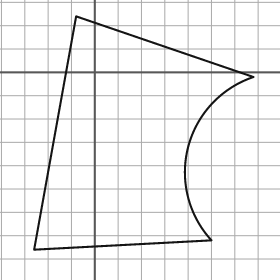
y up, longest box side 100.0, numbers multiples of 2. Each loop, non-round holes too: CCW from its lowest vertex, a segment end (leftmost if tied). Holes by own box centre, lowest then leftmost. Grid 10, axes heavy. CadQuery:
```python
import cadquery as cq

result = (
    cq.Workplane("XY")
    .moveTo(-26.0, -76.0)
    .lineTo(50.0, -72.0)
    .threePointArc((40.0, -32.0), (68.0, -2.0))
    .lineTo(-8.0, 24.0)
    .close()
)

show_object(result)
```